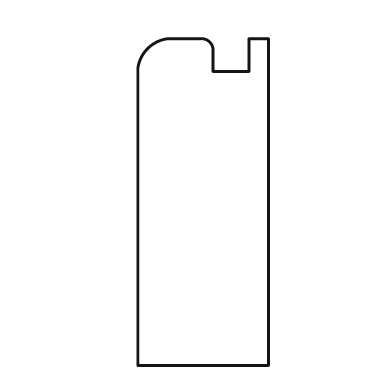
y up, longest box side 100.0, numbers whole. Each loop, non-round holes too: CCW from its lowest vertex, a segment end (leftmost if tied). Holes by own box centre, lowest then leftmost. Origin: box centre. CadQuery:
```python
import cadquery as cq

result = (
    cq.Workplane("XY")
    .moveTo(-20.0, -50.0)
    .lineTo(20.0, -50.0)
    .lineTo(20.0, 50.0)
    .lineTo(14.0, 50.0)
    .lineTo(14.0, 40.0)
    .lineTo(3.0, 40.0)
    .lineTo(3.0, 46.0)
    .threePointArc((2.0, 49.0), (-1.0, 50.0))
    .lineTo(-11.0, 50.0)
    .threePointArc((-17.0, 47.0), (-20.0, 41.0))
    .close()
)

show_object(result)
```